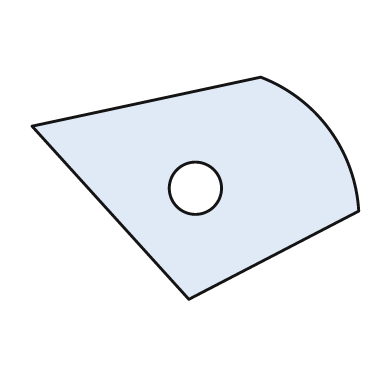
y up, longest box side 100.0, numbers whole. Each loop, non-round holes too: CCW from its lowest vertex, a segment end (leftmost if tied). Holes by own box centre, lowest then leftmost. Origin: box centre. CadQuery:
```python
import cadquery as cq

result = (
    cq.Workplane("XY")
    .moveTo(-2.0, -34.0)
    .lineTo(50.0, -7.0)
    .threePointArc((41.0, 18.0), (20.0, 34.0))
    .lineTo(-50.0, 19.0)
    .close()
    .moveTo(0.0, 0.0)
    .circle(8.0)
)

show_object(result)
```